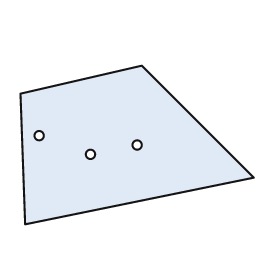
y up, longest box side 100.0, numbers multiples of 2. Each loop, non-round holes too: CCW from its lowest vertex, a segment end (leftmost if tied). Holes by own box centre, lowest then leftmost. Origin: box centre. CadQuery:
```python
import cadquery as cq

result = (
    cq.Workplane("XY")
    .moveTo(-48.0, -34.0)
    .lineTo(50.0, -14.0)
    .lineTo(2.0, 34.0)
    .lineTo(-50.0, 22.0)
    .close()
    .moveTo(-20.0, -4.0)
    .circle(2.0)
    .moveTo(0.0, 0.0)
    .circle(2.0)
    .moveTo(-42.0, 4.0)
    .circle(2.0)
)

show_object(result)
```